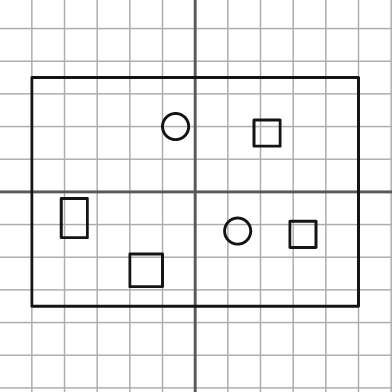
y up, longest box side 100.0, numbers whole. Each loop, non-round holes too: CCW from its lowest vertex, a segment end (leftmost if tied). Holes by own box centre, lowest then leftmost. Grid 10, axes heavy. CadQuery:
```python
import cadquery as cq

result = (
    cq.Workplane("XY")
    .moveTo(-50.0, -35.0)
    .lineTo(50.0, -35.0)
    .lineTo(50.0, 35.0)
    .lineTo(-50.0, 35.0)
    .close()
    .moveTo(-20.0, -29.0)
    .lineTo(-10.0, -29.0)
    .lineTo(-10.0, -19.0)
    .lineTo(-20.0, -19.0)
    .close()
    .moveTo(29.0, -17.0)
    .lineTo(37.0, -17.0)
    .lineTo(37.0, -9.0)
    .lineTo(29.0, -9.0)
    .close()
    .moveTo(13.0, -12.0)
    .circle(4.0)
    .moveTo(-41.0, -14.0)
    .lineTo(-33.0, -14.0)
    .lineTo(-33.0, -2.0)
    .lineTo(-41.0, -2.0)
    .close()
    .moveTo(18.0, 14.0)
    .lineTo(26.0, 14.0)
    .lineTo(26.0, 22.0)
    .lineTo(18.0, 22.0)
    .close()
    .moveTo(-6.0, 20.0)
    .circle(4.0)
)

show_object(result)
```